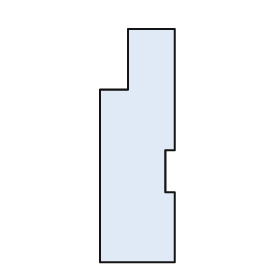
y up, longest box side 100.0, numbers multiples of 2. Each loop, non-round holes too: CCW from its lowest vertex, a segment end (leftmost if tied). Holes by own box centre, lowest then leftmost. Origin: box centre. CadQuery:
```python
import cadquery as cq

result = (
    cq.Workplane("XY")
    .moveTo(-16.0, -50.0)
    .lineTo(16.0, -50.0)
    .lineTo(16.0, -20.0)
    .lineTo(12.0, -20.0)
    .lineTo(12.0, -2.0)
    .lineTo(16.0, -2.0)
    .lineTo(16.0, 50.0)
    .lineTo(-4.0, 50.0)
    .lineTo(-4.0, 24.0)
    .lineTo(-16.0, 24.0)
    .close()
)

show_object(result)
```